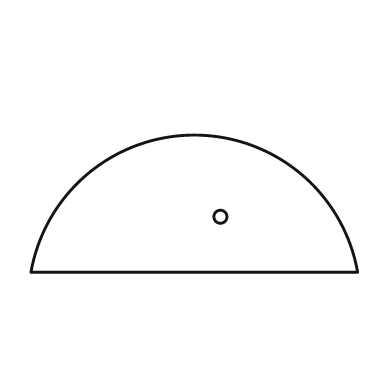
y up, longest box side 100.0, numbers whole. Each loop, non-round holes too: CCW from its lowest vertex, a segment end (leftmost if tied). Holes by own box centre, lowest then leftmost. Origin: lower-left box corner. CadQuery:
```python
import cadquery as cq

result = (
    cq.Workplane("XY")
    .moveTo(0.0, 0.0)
    .lineTo(100.0, 0.0)
    .threePointArc((50.0, 42.0), (0.0, 0.0))
    .close()
    .moveTo(58.0, 17.0)
    .circle(2.0)
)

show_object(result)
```